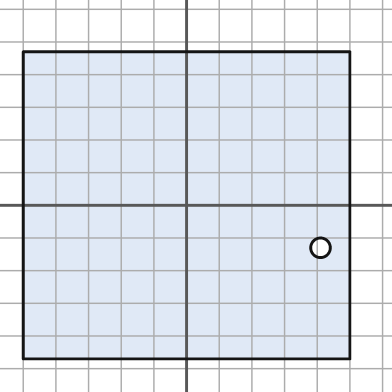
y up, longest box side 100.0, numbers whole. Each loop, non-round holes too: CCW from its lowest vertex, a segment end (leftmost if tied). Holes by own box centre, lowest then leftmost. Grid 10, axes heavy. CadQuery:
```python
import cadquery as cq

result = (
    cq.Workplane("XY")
    .moveTo(-50.0, -47.0)
    .lineTo(50.0, -47.0)
    .lineTo(50.0, 47.0)
    .lineTo(-50.0, 47.0)
    .close()
    .moveTo(41.0, -13.0)
    .circle(3.0)
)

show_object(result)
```